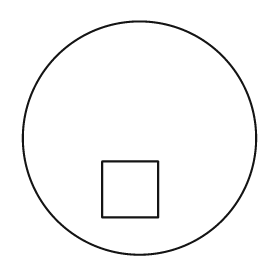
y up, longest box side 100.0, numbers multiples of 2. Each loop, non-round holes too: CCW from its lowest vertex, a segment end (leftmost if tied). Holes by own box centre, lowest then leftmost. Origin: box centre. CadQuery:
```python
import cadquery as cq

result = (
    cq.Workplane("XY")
    .moveTo(0.0, 0.0)
    .circle(50.0)
    .moveTo(-16.0, -34.0)
    .lineTo(8.0, -34.0)
    .lineTo(8.0, -10.0)
    .lineTo(-16.0, -10.0)
    .close()
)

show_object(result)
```